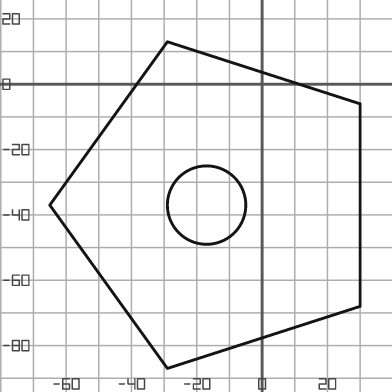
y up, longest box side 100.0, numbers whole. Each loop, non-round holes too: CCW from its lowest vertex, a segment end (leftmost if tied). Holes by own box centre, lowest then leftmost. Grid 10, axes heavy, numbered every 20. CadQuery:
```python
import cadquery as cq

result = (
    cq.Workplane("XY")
    .moveTo(-29.0, -87.0)
    .lineTo(30.0, -68.0)
    .lineTo(30.0, -6.0)
    .lineTo(-29.0, 13.0)
    .lineTo(-65.0, -37.0)
    .close()
    .moveTo(-17.0, -37.0)
    .circle(12.0)
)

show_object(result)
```